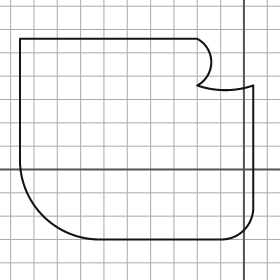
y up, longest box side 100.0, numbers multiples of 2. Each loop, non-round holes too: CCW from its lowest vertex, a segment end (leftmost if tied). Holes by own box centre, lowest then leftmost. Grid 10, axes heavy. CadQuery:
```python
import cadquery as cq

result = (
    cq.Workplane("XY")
    .moveTo(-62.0, -30.0)
    .lineTo(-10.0, -30.0)
    .threePointArc((0.0, -26.0), (4.0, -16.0))
    .lineTo(4.0, 36.0)
    .threePointArc((-8.0, 34.0), (-20.0, 36.0))
    .threePointArc((-14.0, 46.0), (-20.0, 56.0))
    .lineTo(-96.0, 56.0)
    .lineTo(-96.0, 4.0)
    .threePointArc((-86.0, -20.0), (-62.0, -30.0))
    .close()
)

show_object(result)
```